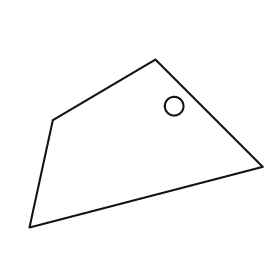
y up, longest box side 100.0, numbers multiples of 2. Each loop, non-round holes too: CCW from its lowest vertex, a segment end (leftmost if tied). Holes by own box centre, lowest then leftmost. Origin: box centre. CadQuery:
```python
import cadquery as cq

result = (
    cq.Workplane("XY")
    .moveTo(-50.0, -36.0)
    .lineTo(50.0, -10.0)
    .lineTo(4.0, 36.0)
    .lineTo(-40.0, 10.0)
    .close()
    .moveTo(12.0, 16.0)
    .circle(4.0)
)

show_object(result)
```